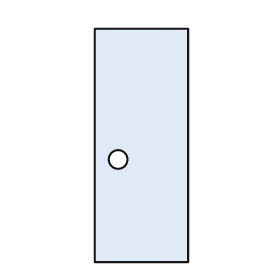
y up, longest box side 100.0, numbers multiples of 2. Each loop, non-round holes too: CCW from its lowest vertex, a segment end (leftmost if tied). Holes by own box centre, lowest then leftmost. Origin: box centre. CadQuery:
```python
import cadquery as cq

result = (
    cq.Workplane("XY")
    .moveTo(-20.0, -50.0)
    .lineTo(20.0, -50.0)
    .lineTo(20.0, 50.0)
    .lineTo(-20.0, 50.0)
    .close()
    .moveTo(-10.0, -6.0)
    .circle(4.0)
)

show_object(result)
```